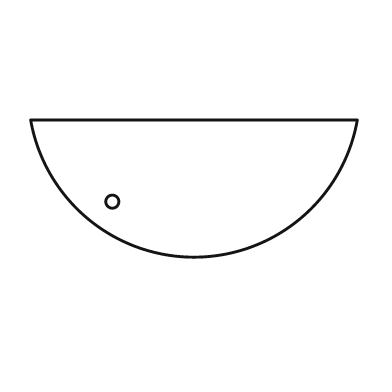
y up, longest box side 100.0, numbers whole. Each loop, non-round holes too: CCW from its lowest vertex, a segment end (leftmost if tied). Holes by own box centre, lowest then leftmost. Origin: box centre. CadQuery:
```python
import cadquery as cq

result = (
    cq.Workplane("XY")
    .moveTo(-50.0, 21.0)
    .threePointArc((0.0, -21.0), (50.0, 21.0))
    .close()
    .moveTo(-25.0, -4.0)
    .circle(2.0)
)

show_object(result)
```